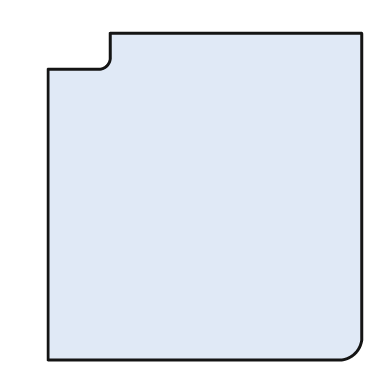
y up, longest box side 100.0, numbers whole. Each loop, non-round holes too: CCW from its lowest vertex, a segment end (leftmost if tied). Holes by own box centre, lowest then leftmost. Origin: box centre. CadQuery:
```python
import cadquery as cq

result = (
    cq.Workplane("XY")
    .moveTo(-48.0, -50.0)
    .lineTo(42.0, -50.0)
    .threePointArc((46.0, -48.0), (48.0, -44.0))
    .lineTo(48.0, 50.0)
    .lineTo(-29.0, 50.0)
    .lineTo(-29.0, 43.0)
    .threePointArc((-30.0, 40.0), (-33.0, 39.0))
    .lineTo(-48.0, 39.0)
    .close()
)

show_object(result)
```